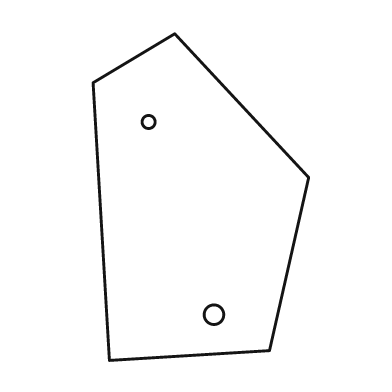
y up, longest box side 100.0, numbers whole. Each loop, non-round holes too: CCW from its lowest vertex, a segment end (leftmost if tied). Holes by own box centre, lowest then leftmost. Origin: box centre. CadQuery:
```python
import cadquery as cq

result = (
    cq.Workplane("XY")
    .moveTo(-28.0, -50.0)
    .lineTo(21.0, -47.0)
    .lineTo(33.0, 6.0)
    .lineTo(-8.0, 50.0)
    .lineTo(-33.0, 35.0)
    .close()
    .moveTo(4.0, -36.0)
    .circle(3.0)
    .moveTo(-16.0, 23.0)
    .circle(2.0)
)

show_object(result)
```